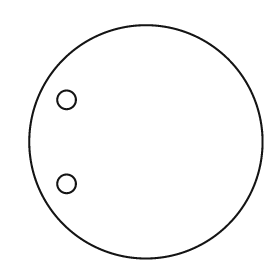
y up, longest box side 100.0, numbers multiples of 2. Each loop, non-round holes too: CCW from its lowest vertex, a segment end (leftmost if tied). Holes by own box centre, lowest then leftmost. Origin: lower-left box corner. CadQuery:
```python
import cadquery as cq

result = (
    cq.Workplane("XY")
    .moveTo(50.0, 50.0)
    .circle(50.0)
    .moveTo(16.0, 32.0)
    .circle(4.0)
    .moveTo(16.0, 68.0)
    .circle(4.0)
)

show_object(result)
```